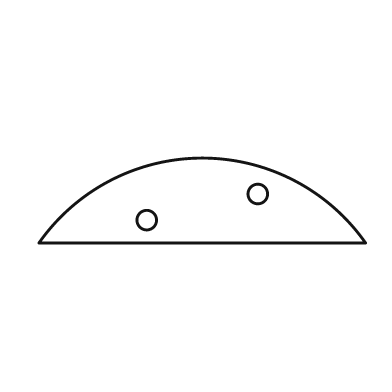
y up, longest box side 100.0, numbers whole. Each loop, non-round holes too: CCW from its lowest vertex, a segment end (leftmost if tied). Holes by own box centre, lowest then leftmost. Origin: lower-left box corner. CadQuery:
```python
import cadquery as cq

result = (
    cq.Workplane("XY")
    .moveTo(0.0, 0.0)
    .lineTo(100.0, 0.0)
    .threePointArc((50.0, 26.0), (0.0, 0.0))
    .close()
    .moveTo(33.0, 7.0)
    .circle(3.0)
    .moveTo(67.0, 15.0)
    .circle(3.0)
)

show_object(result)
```